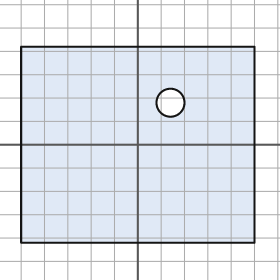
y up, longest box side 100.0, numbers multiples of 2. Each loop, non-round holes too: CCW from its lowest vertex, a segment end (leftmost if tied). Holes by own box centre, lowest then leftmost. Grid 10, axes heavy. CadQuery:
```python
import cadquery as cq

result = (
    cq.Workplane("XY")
    .moveTo(-50.0, -42.0)
    .lineTo(50.0, -42.0)
    .lineTo(50.0, 42.0)
    .lineTo(-50.0, 42.0)
    .close()
    .moveTo(14.0, 18.0)
    .circle(6.0)
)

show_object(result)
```